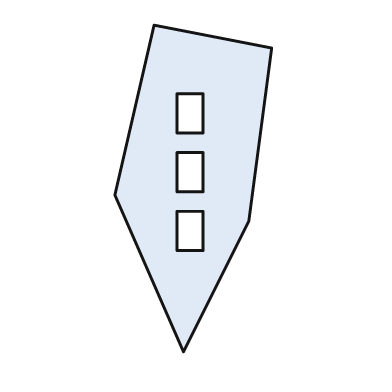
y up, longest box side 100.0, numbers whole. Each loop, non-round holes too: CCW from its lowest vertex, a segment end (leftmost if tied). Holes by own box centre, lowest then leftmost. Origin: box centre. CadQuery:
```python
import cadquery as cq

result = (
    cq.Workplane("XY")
    .moveTo(-3.0, -50.0)
    .lineTo(17.0, -10.0)
    .lineTo(24.0, 43.0)
    .lineTo(-12.0, 50.0)
    .lineTo(-24.0, -2.0)
    .close()
    .moveTo(-5.0, -19.0)
    .lineTo(3.0, -19.0)
    .lineTo(3.0, -7.0)
    .lineTo(-5.0, -7.0)
    .close()
    .moveTo(-5.0, -1.0)
    .lineTo(3.0, -1.0)
    .lineTo(3.0, 11.0)
    .lineTo(-5.0, 11.0)
    .close()
    .moveTo(-5.0, 17.0)
    .lineTo(3.0, 17.0)
    .lineTo(3.0, 29.0)
    .lineTo(-5.0, 29.0)
    .close()
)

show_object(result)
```